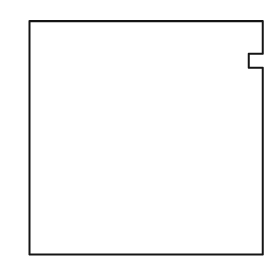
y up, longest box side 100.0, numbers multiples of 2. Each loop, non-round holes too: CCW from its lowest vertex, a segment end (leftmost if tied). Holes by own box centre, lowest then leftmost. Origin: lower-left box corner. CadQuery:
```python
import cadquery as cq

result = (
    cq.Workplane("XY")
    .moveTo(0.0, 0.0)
    .lineTo(100.0, 0.0)
    .lineTo(100.0, 80.0)
    .lineTo(94.0, 80.0)
    .lineTo(94.0, 86.0)
    .lineTo(100.0, 86.0)
    .lineTo(100.0, 100.0)
    .lineTo(0.0, 100.0)
    .close()
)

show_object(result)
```